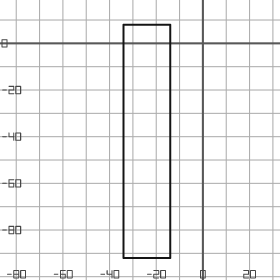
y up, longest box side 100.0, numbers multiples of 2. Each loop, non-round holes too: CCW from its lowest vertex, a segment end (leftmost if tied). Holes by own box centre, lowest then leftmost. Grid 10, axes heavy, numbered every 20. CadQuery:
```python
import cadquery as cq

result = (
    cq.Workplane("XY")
    .moveTo(-34.0, -92.0)
    .lineTo(-14.0, -92.0)
    .lineTo(-14.0, 8.0)
    .lineTo(-34.0, 8.0)
    .close()
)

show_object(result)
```